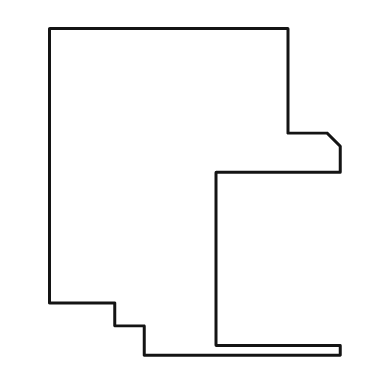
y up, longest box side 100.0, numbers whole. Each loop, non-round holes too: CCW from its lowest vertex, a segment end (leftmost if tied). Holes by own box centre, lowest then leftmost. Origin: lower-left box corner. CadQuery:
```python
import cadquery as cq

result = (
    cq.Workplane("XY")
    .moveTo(29.0, 0.0)
    .lineTo(89.0, 0.0)
    .lineTo(89.0, 3.0)
    .lineTo(51.0, 3.0)
    .lineTo(51.0, 56.0)
    .lineTo(89.0, 56.0)
    .lineTo(89.0, 64.0)
    .lineTo(85.0, 68.0)
    .lineTo(73.0, 68.0)
    .lineTo(73.0, 100.0)
    .lineTo(0.0, 100.0)
    .lineTo(0.0, 16.0)
    .lineTo(20.0, 16.0)
    .lineTo(20.0, 9.0)
    .lineTo(29.0, 9.0)
    .close()
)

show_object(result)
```